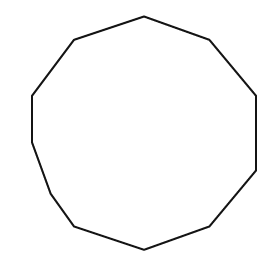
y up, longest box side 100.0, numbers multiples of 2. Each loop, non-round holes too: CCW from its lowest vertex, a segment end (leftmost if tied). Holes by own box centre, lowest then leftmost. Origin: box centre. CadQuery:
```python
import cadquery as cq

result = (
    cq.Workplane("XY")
    .moveTo(0.0, -50.0)
    .lineTo(28.0, -40.0)
    .lineTo(48.0, -16.0)
    .lineTo(48.0, 16.0)
    .lineTo(28.0, 40.0)
    .lineTo(0.0, 50.0)
    .lineTo(-30.0, 40.0)
    .lineTo(-48.0, 16.0)
    .lineTo(-48.0, -4.0)
    .lineTo(-40.0, -26.0)
    .lineTo(-30.0, -40.0)
    .close()
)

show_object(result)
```